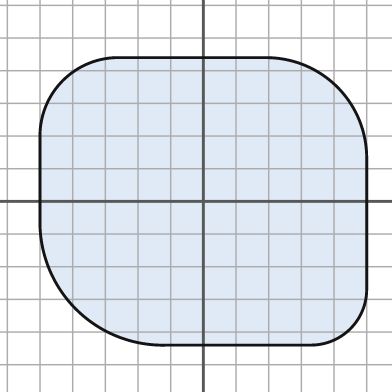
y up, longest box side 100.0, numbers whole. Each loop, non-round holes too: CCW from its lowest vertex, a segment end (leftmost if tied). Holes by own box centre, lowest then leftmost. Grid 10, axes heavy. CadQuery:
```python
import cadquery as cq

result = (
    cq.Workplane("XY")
    .moveTo(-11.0, -44.0)
    .lineTo(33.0, -44.0)
    .threePointArc((45.0, -39.0), (50.0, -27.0))
    .lineTo(50.0, 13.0)
    .threePointArc((41.0, 35.0), (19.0, 44.0))
    .lineTo(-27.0, 44.0)
    .threePointArc((-43.0, 37.0), (-50.0, 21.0))
    .lineTo(-50.0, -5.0)
    .threePointArc((-39.0, -33.0), (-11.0, -44.0))
    .close()
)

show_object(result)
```